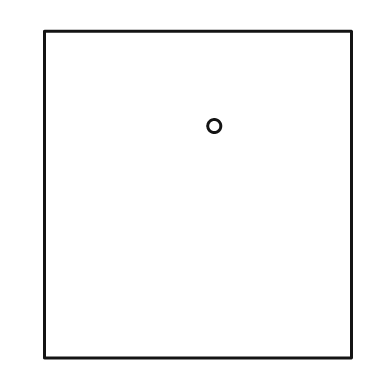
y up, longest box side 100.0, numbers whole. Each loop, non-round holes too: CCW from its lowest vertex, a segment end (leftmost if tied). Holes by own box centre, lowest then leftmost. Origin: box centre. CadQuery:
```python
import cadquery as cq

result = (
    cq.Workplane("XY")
    .moveTo(-47.0, -50.0)
    .lineTo(47.0, -50.0)
    .lineTo(47.0, 50.0)
    .lineTo(-47.0, 50.0)
    .close()
    .moveTo(5.0, 21.0)
    .circle(2.0)
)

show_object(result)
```